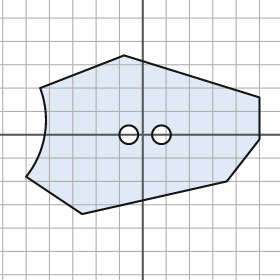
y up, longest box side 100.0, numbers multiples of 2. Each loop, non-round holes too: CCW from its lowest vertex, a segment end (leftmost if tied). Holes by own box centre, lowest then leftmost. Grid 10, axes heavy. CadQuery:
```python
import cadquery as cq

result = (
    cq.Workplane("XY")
    .moveTo(-26.0, -34.0)
    .lineTo(36.0, -20.0)
    .lineTo(50.0, -2.0)
    .lineTo(50.0, 16.0)
    .lineTo(-8.0, 34.0)
    .lineTo(-44.0, 20.0)
    .threePointArc((-42.0, 0.0), (-50.0, -18.0))
    .close()
    .moveTo(-6.0, 0.0)
    .circle(4.0)
    .moveTo(8.0, 0.0)
    .circle(4.0)
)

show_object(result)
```